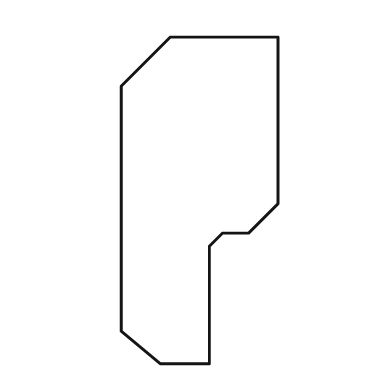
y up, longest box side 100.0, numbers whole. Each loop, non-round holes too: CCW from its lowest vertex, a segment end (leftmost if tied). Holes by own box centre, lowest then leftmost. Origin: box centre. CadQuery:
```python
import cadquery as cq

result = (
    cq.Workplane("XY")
    .moveTo(-12.0, -50.0)
    .lineTo(3.0, -50.0)
    .lineTo(3.0, -14.0)
    .lineTo(7.0, -10.0)
    .lineTo(15.0, -10.0)
    .lineTo(24.0, -1.0)
    .lineTo(24.0, 50.0)
    .lineTo(-9.0, 50.0)
    .lineTo(-24.0, 35.0)
    .lineTo(-24.0, -40.0)
    .close()
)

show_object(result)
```